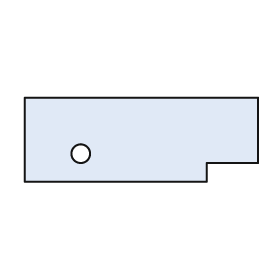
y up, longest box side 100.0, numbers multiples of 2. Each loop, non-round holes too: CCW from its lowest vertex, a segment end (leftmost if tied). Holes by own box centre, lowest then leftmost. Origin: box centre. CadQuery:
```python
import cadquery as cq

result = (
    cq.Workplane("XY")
    .moveTo(-50.0, -18.0)
    .lineTo(28.0, -18.0)
    .lineTo(28.0, -10.0)
    .lineTo(50.0, -10.0)
    .lineTo(50.0, 18.0)
    .lineTo(-50.0, 18.0)
    .close()
    .moveTo(-26.0, -6.0)
    .circle(4.0)
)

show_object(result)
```